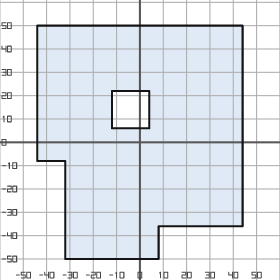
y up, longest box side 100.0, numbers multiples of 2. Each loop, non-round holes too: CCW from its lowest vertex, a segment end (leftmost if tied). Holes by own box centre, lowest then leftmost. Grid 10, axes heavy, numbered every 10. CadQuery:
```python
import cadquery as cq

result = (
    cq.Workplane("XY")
    .moveTo(-32.0, -50.0)
    .lineTo(8.0, -50.0)
    .lineTo(8.0, -36.0)
    .lineTo(44.0, -36.0)
    .lineTo(44.0, 50.0)
    .lineTo(-44.0, 50.0)
    .lineTo(-44.0, -8.0)
    .lineTo(-32.0, -8.0)
    .close()
    .moveTo(-12.0, 6.0)
    .lineTo(4.0, 6.0)
    .lineTo(4.0, 22.0)
    .lineTo(-12.0, 22.0)
    .close()
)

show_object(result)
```